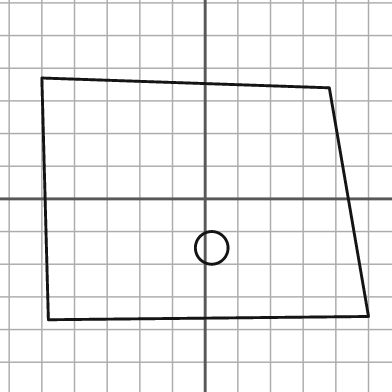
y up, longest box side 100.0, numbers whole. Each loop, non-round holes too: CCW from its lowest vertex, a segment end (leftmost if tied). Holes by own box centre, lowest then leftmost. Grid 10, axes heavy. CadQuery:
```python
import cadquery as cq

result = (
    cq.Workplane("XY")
    .moveTo(-48.0, -37.0)
    .lineTo(50.0, -36.0)
    .lineTo(38.0, 34.0)
    .lineTo(-50.0, 37.0)
    .close()
    .moveTo(2.0, -15.0)
    .circle(5.0)
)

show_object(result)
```